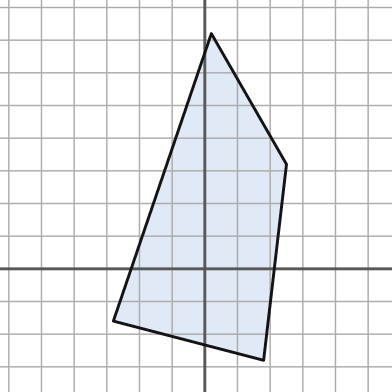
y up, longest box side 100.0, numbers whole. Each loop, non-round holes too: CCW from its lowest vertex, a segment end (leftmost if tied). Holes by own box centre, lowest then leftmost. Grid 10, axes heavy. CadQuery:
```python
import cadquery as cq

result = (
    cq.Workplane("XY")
    .moveTo(18.0, -28.0)
    .lineTo(25.0, 32.0)
    .lineTo(2.0, 72.0)
    .lineTo(-28.0, -16.0)
    .close()
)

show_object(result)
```